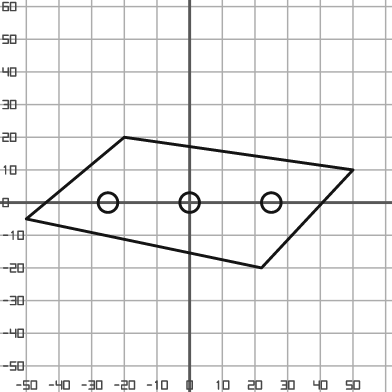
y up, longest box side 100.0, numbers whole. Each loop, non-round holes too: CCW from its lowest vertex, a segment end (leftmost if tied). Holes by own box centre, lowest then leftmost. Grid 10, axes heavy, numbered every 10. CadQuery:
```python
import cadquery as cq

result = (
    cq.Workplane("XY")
    .moveTo(22.0, -20.0)
    .lineTo(50.0, 10.0)
    .lineTo(-20.0, 20.0)
    .lineTo(-50.0, -5.0)
    .close()
    .moveTo(-25.0, 0.0)
    .circle(3.0)
    .moveTo(0.0, 0.0)
    .circle(3.0)
    .moveTo(25.0, 0.0)
    .circle(3.0)
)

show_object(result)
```